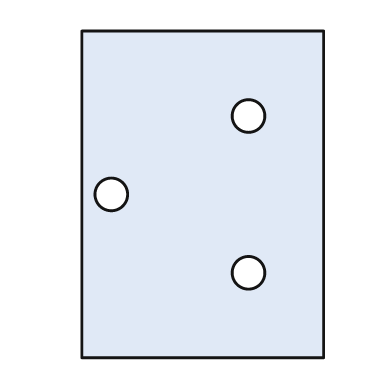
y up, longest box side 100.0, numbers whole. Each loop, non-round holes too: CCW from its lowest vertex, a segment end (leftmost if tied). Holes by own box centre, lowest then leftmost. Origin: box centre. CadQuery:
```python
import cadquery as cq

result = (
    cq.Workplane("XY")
    .moveTo(-37.0, -50.0)
    .lineTo(37.0, -50.0)
    .lineTo(37.0, 50.0)
    .lineTo(-37.0, 50.0)
    .close()
    .moveTo(14.0, -24.0)
    .circle(5.0)
    .moveTo(-28.0, 0.0)
    .circle(5.0)
    .moveTo(14.0, 24.0)
    .circle(5.0)
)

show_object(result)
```